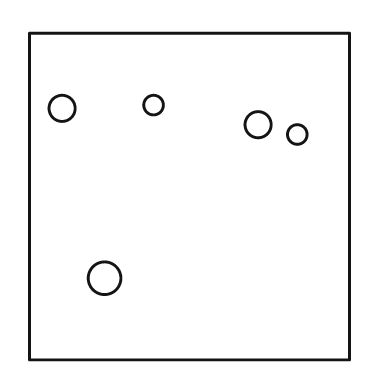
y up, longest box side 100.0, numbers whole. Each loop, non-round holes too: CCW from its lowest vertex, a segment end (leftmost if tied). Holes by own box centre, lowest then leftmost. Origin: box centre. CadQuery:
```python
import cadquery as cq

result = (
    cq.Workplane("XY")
    .moveTo(-49.0, -50.0)
    .lineTo(49.0, -50.0)
    .lineTo(49.0, 50.0)
    .lineTo(-49.0, 50.0)
    .close()
    .moveTo(-26.0, -25.0)
    .circle(5.0)
    .moveTo(33.0, 19.0)
    .circle(3.0)
    .moveTo(21.0, 22.0)
    .circle(4.0)
    .moveTo(-39.0, 27.0)
    .circle(4.0)
    .moveTo(-11.0, 28.0)
    .circle(3.0)
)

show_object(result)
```